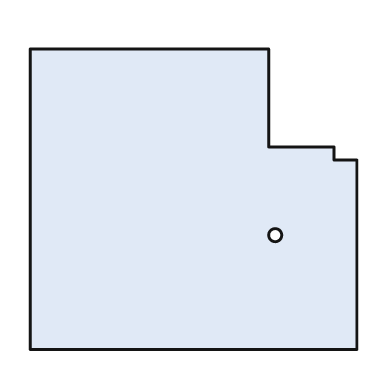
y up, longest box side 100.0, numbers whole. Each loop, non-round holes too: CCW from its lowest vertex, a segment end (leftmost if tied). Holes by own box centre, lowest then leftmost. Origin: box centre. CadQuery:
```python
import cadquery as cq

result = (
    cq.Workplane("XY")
    .moveTo(-50.0, -46.0)
    .lineTo(50.0, -46.0)
    .lineTo(50.0, 12.0)
    .lineTo(43.0, 12.0)
    .lineTo(43.0, 16.0)
    .lineTo(23.0, 16.0)
    .lineTo(23.0, 46.0)
    .lineTo(-50.0, 46.0)
    .close()
    .moveTo(25.0, -11.0)
    .circle(2.0)
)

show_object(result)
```